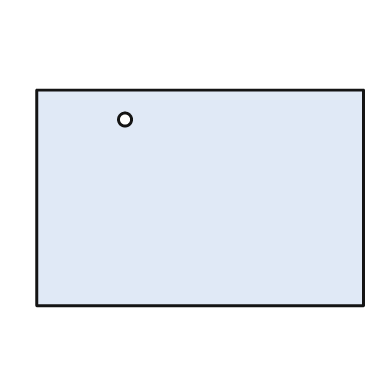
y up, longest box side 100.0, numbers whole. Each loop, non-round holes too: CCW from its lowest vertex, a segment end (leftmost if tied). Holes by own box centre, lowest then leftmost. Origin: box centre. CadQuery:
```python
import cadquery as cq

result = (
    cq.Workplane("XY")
    .moveTo(-50.0, -33.0)
    .lineTo(50.0, -33.0)
    .lineTo(50.0, 33.0)
    .lineTo(-50.0, 33.0)
    .close()
    .moveTo(-23.0, 24.0)
    .circle(2.0)
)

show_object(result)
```